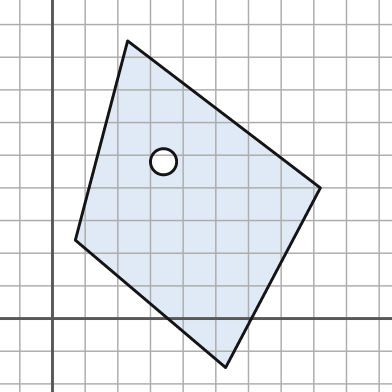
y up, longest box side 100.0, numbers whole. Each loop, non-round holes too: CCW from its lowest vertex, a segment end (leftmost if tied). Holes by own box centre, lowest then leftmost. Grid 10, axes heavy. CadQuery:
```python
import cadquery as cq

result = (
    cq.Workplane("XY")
    .moveTo(53.0, -15.0)
    .lineTo(82.0, 40.0)
    .lineTo(23.0, 85.0)
    .lineTo(7.0, 24.0)
    .close()
    .moveTo(34.0, 48.0)
    .circle(4.0)
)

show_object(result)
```